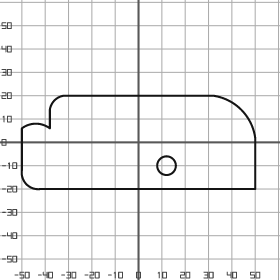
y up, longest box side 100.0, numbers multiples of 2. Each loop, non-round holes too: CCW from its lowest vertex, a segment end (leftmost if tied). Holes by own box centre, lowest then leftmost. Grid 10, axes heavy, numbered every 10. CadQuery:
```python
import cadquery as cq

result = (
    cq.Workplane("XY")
    .moveTo(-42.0, -20.0)
    .lineTo(50.0, -20.0)
    .lineTo(50.0, 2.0)
    .threePointArc((44.0, 14.0), (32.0, 20.0))
    .lineTo(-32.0, 20.0)
    .threePointArc((-36.0, 18.0), (-38.0, 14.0))
    .lineTo(-38.0, 6.0)
    .threePointArc((-44.0, 8.0), (-50.0, 6.0))
    .lineTo(-50.0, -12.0)
    .threePointArc((-48.0, -18.0), (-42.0, -20.0))
    .close()
    .moveTo(12.0, -10.0)
    .circle(4.0)
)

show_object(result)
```